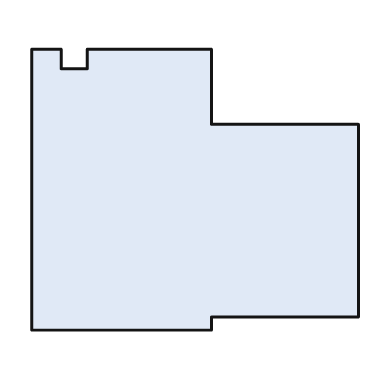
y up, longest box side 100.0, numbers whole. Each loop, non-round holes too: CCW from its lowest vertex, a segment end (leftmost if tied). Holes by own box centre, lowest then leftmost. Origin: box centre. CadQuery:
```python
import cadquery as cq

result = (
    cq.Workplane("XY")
    .moveTo(-50.0, -43.0)
    .lineTo(5.0, -43.0)
    .lineTo(5.0, -39.0)
    .lineTo(50.0, -39.0)
    .lineTo(50.0, 20.0)
    .lineTo(5.0, 20.0)
    .lineTo(5.0, 43.0)
    .lineTo(-33.0, 43.0)
    .lineTo(-33.0, 37.0)
    .lineTo(-41.0, 37.0)
    .lineTo(-41.0, 43.0)
    .lineTo(-50.0, 43.0)
    .close()
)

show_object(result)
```